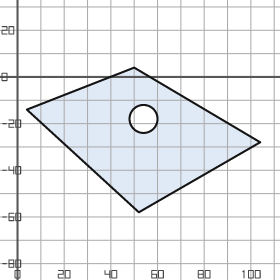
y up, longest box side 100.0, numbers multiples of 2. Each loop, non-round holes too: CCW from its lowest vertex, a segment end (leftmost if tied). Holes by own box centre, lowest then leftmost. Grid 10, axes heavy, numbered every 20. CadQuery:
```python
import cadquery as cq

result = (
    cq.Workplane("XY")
    .moveTo(52.0, -58.0)
    .lineTo(104.0, -28.0)
    .lineTo(50.0, 4.0)
    .lineTo(4.0, -14.0)
    .close()
    .moveTo(54.0, -18.0)
    .circle(6.0)
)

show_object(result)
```